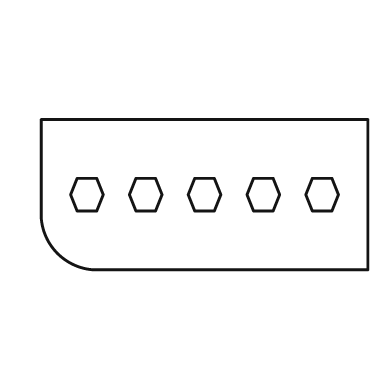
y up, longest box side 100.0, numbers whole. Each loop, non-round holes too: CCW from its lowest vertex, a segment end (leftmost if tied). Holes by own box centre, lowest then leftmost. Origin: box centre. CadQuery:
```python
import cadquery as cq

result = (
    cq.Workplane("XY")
    .moveTo(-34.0, -23.0)
    .lineTo(50.0, -23.0)
    .lineTo(50.0, 23.0)
    .lineTo(-50.0, 23.0)
    .lineTo(-50.0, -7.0)
    .threePointArc((-45.0, -18.0), (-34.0, -23.0))
    .close()
    .moveTo(-39.0, -5.0)
    .lineTo(-33.0, -5.0)
    .lineTo(-31.0, 0.0)
    .lineTo(-33.0, 5.0)
    .lineTo(-39.0, 5.0)
    .lineTo(-41.0, 0.0)
    .close()
    .moveTo(-21.0, -5.0)
    .lineTo(-15.0, -5.0)
    .lineTo(-13.0, 0.0)
    .lineTo(-15.0, 5.0)
    .lineTo(-21.0, 5.0)
    .lineTo(-23.0, 0.0)
    .close()
    .moveTo(-3.0, -5.0)
    .lineTo(3.0, -5.0)
    .lineTo(5.0, 0.0)
    .lineTo(3.0, 5.0)
    .lineTo(-3.0, 5.0)
    .lineTo(-5.0, 0.0)
    .close()
    .moveTo(15.0, -5.0)
    .lineTo(21.0, -5.0)
    .lineTo(23.0, 0.0)
    .lineTo(21.0, 5.0)
    .lineTo(15.0, 5.0)
    .lineTo(13.0, 0.0)
    .close()
    .moveTo(33.0, -5.0)
    .lineTo(39.0, -5.0)
    .lineTo(41.0, 0.0)
    .lineTo(39.0, 5.0)
    .lineTo(33.0, 5.0)
    .lineTo(31.0, 0.0)
    .close()
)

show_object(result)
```